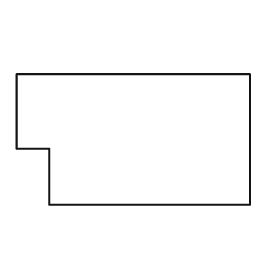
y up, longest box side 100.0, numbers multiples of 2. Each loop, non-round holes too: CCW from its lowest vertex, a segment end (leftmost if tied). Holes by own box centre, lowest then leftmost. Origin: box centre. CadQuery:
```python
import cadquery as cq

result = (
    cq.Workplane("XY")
    .moveTo(-36.0, -28.0)
    .lineTo(50.0, -28.0)
    .lineTo(50.0, 28.0)
    .lineTo(-50.0, 28.0)
    .lineTo(-50.0, -4.0)
    .lineTo(-36.0, -4.0)
    .close()
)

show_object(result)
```